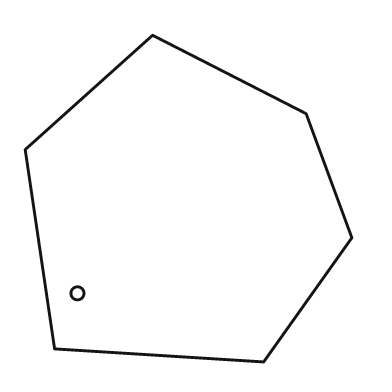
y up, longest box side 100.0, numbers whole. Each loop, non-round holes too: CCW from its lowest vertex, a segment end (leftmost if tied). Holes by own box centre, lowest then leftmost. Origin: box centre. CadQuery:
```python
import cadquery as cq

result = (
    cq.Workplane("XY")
    .moveTo(23.0, -50.0)
    .lineTo(50.0, -12.0)
    .lineTo(36.0, 26.0)
    .lineTo(-11.0, 50.0)
    .lineTo(-50.0, 15.0)
    .lineTo(-41.0, -46.0)
    .close()
    .moveTo(-34.0, -29.0)
    .circle(2.0)
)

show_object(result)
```